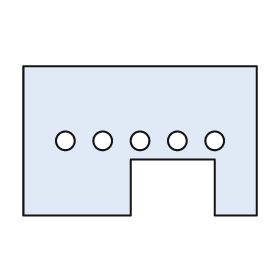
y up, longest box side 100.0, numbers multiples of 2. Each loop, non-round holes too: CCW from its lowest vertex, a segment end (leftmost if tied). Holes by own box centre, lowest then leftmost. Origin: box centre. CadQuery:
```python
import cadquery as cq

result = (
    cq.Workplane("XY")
    .moveTo(-50.0, -32.0)
    .lineTo(-4.0, -32.0)
    .lineTo(-4.0, -8.0)
    .lineTo(32.0, -8.0)
    .lineTo(32.0, -32.0)
    .lineTo(50.0, -32.0)
    .lineTo(50.0, 32.0)
    .lineTo(-50.0, 32.0)
    .close()
    .moveTo(-32.0, 0.0)
    .circle(4.0)
    .moveTo(-16.0, 0.0)
    .circle(4.0)
    .moveTo(0.0, 0.0)
    .circle(4.0)
    .moveTo(16.0, 0.0)
    .circle(4.0)
    .moveTo(32.0, 0.0)
    .circle(4.0)
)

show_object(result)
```